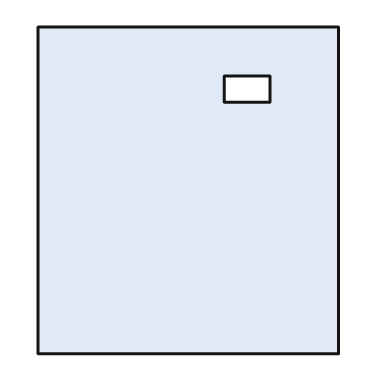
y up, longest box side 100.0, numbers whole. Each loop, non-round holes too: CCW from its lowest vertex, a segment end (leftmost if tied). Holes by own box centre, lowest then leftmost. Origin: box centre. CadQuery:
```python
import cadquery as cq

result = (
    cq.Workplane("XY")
    .moveTo(-46.0, -50.0)
    .lineTo(46.0, -50.0)
    .lineTo(46.0, 50.0)
    .lineTo(-46.0, 50.0)
    .close()
    .moveTo(11.0, 27.0)
    .lineTo(25.0, 27.0)
    .lineTo(25.0, 35.0)
    .lineTo(11.0, 35.0)
    .close()
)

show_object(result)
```